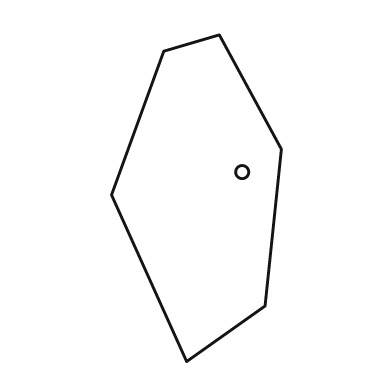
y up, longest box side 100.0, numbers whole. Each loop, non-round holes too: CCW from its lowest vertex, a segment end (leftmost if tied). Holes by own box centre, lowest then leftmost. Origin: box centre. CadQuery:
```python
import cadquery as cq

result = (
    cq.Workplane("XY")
    .moveTo(-3.0, -50.0)
    .lineTo(21.0, -33.0)
    .lineTo(26.0, 15.0)
    .lineTo(7.0, 50.0)
    .lineTo(-10.0, 45.0)
    .lineTo(-26.0, 1.0)
    .close()
    .moveTo(14.0, 8.0)
    .circle(2.0)
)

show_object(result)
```